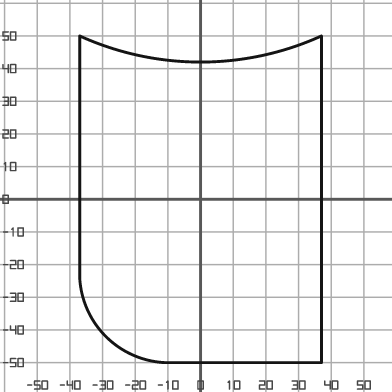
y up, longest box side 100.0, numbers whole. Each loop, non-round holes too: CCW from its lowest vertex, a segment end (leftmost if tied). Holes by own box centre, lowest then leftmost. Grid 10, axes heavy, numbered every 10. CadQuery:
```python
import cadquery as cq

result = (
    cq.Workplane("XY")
    .moveTo(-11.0, -50.0)
    .lineTo(37.0, -50.0)
    .lineTo(37.0, 50.0)
    .threePointArc((0.0, 42.0), (-37.0, 50.0))
    .lineTo(-37.0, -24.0)
    .threePointArc((-29.0, -42.0), (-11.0, -50.0))
    .close()
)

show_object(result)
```